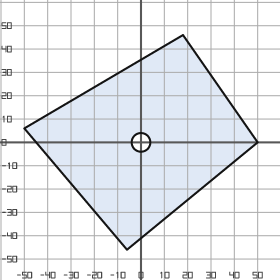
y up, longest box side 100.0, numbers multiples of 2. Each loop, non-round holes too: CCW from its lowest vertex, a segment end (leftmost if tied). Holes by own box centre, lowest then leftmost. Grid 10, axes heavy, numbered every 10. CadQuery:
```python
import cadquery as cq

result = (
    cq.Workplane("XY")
    .moveTo(-6.0, -46.0)
    .lineTo(50.0, 0.0)
    .lineTo(18.0, 46.0)
    .lineTo(-50.0, 6.0)
    .close()
    .moveTo(0.0, 0.0)
    .circle(4.0)
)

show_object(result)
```